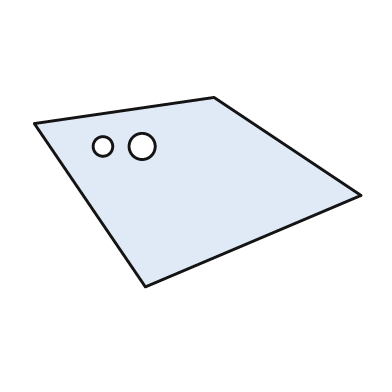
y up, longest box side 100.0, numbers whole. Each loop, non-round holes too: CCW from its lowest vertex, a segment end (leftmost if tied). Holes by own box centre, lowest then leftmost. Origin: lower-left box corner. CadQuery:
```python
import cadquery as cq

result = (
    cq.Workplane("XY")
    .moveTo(34.0, 0.0)
    .lineTo(100.0, 28.0)
    .lineTo(55.0, 58.0)
    .lineTo(0.0, 50.0)
    .close()
    .moveTo(21.0, 43.0)
    .circle(3.0)
    .moveTo(33.0, 43.0)
    .circle(4.0)
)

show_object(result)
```